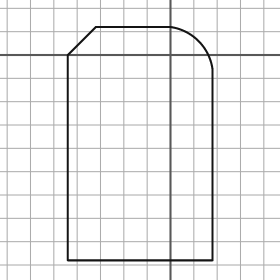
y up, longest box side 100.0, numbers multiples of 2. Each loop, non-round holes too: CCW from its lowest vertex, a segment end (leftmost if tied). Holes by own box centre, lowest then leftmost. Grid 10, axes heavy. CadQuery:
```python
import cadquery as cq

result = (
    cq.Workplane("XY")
    .moveTo(-44.0, -88.0)
    .lineTo(18.0, -88.0)
    .lineTo(18.0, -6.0)
    .threePointArc((12.0, 6.0), (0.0, 12.0))
    .lineTo(-32.0, 12.0)
    .lineTo(-44.0, 0.0)
    .close()
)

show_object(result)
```